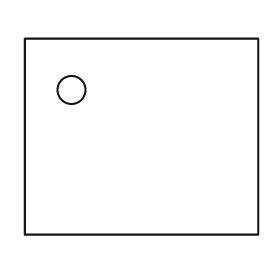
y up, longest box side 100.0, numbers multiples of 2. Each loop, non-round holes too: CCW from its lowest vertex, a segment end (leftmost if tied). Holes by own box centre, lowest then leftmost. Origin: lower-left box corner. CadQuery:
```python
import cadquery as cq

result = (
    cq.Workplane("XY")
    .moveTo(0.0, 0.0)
    .lineTo(100.0, 0.0)
    .lineTo(100.0, 84.0)
    .lineTo(0.0, 84.0)
    .close()
    .moveTo(20.0, 62.0)
    .circle(6.0)
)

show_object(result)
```